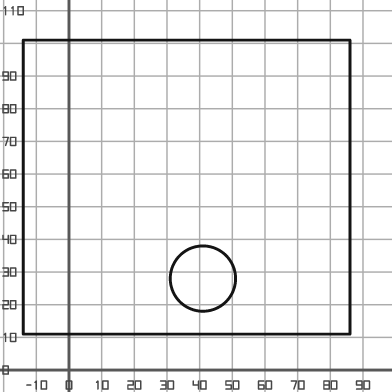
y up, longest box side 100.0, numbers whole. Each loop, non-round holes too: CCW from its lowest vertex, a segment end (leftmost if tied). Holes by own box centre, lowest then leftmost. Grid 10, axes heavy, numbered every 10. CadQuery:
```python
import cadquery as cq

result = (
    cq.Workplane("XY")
    .moveTo(-14.0, 11.0)
    .lineTo(86.0, 11.0)
    .lineTo(86.0, 101.0)
    .lineTo(-14.0, 101.0)
    .close()
    .moveTo(41.0, 28.0)
    .circle(10.0)
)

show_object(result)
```